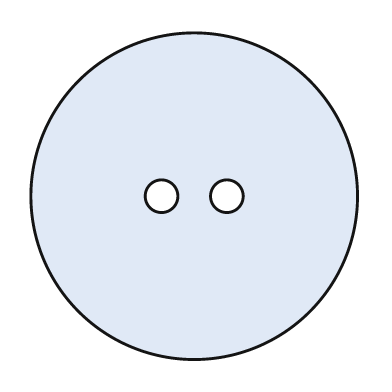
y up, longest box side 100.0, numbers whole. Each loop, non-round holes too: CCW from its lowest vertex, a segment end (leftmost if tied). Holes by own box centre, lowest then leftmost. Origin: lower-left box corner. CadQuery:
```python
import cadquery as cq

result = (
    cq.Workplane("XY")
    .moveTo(50.0, 50.0)
    .circle(50.0)
    .moveTo(40.0, 50.0)
    .circle(5.0)
    .moveTo(60.0, 50.0)
    .circle(5.0)
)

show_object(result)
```